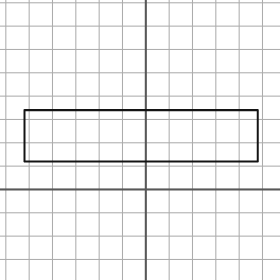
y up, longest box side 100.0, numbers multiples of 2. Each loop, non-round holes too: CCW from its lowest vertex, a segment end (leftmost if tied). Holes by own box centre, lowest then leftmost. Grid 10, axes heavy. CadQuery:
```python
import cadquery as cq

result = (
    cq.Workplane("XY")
    .moveTo(-52.0, 12.0)
    .lineTo(48.0, 12.0)
    .lineTo(48.0, 34.0)
    .lineTo(-52.0, 34.0)
    .close()
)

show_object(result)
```